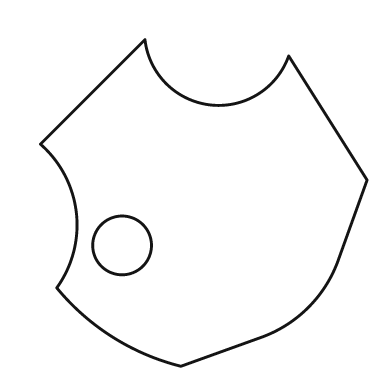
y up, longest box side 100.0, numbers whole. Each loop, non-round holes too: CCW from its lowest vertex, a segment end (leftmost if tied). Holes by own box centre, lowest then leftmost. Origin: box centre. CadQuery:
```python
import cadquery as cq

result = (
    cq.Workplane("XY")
    .moveTo(-7.0, -50.0)
    .lineTo(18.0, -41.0)
    .threePointArc((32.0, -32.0), (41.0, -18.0))
    .lineTo(50.0, 7.0)
    .lineTo(26.0, 45.0)
    .threePointArc((2.0, 30.0), (-18.0, 50.0))
    .lineTo(-50.0, 18.0)
    .threePointArc((-39.0, -3.0), (-45.0, -26.0))
    .threePointArc((-28.0, -41.0), (-7.0, -50.0))
    .close()
    .moveTo(-25.0, -13.0)
    .circle(9.0)
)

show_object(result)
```